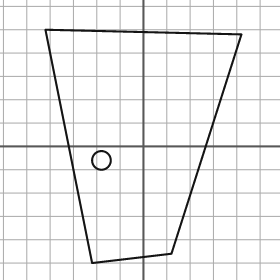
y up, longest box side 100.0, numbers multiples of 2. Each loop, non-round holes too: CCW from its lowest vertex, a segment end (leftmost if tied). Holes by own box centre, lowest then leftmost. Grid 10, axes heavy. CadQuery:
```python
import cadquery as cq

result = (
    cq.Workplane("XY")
    .moveTo(-22.0, -50.0)
    .lineTo(12.0, -46.0)
    .lineTo(42.0, 48.0)
    .lineTo(-42.0, 50.0)
    .close()
    .moveTo(-18.0, -6.0)
    .circle(4.0)
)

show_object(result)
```